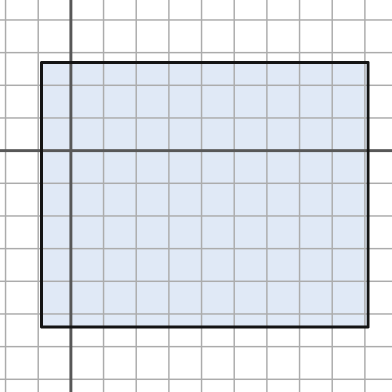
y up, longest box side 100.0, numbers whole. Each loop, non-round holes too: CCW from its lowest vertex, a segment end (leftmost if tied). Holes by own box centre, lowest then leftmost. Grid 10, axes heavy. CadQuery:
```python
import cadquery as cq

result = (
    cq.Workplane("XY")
    .moveTo(-9.0, -54.0)
    .lineTo(91.0, -54.0)
    .lineTo(91.0, 27.0)
    .lineTo(-9.0, 27.0)
    .close()
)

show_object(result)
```